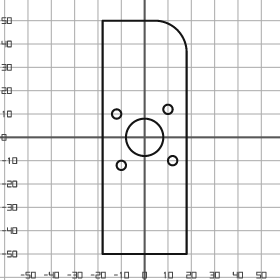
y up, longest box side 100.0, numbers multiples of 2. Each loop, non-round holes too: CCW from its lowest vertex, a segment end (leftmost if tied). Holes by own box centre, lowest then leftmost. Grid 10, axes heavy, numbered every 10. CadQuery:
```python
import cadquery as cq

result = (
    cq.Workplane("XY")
    .moveTo(-18.0, -50.0)
    .lineTo(18.0, -50.0)
    .lineTo(18.0, 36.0)
    .threePointArc((14.0, 46.0), (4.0, 50.0))
    .lineTo(-18.0, 50.0)
    .close()
    .moveTo(-10.0, -12.0)
    .circle(2.0)
    .moveTo(12.0, -10.0)
    .circle(2.0)
    .moveTo(0.0, 0.0)
    .circle(8.0)
    .moveTo(-12.0, 10.0)
    .circle(2.0)
    .moveTo(10.0, 12.0)
    .circle(2.0)
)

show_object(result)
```